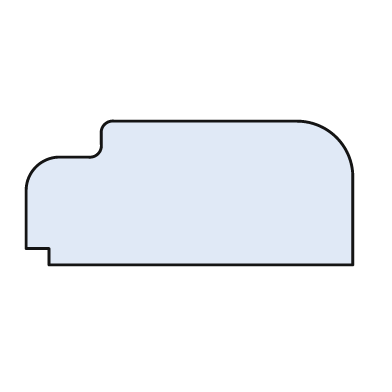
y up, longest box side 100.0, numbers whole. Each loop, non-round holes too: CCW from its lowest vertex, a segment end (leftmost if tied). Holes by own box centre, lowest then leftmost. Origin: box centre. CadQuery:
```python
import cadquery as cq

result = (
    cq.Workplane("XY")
    .moveTo(-43.0, -22.0)
    .lineTo(50.0, -22.0)
    .lineTo(50.0, 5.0)
    .threePointArc((45.0, 17.0), (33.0, 22.0))
    .lineTo(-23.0, 22.0)
    .threePointArc((-26.0, 21.0), (-27.0, 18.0))
    .lineTo(-27.0, 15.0)
    .threePointArc((-28.0, 12.0), (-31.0, 11.0))
    .lineTo(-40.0, 11.0)
    .threePointArc((-47.0, 8.0), (-50.0, 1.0))
    .lineTo(-50.0, -17.0)
    .lineTo(-43.0, -17.0)
    .close()
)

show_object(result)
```